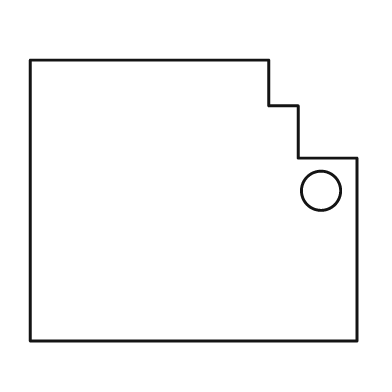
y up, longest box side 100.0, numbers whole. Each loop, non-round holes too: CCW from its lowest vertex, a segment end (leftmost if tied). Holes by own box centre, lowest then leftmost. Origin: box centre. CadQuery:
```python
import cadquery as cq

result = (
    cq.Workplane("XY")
    .moveTo(-50.0, -43.0)
    .lineTo(50.0, -43.0)
    .lineTo(50.0, 13.0)
    .lineTo(32.0, 13.0)
    .lineTo(32.0, 29.0)
    .lineTo(23.0, 29.0)
    .lineTo(23.0, 43.0)
    .lineTo(-50.0, 43.0)
    .close()
    .moveTo(39.0, 3.0)
    .circle(6.0)
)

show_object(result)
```